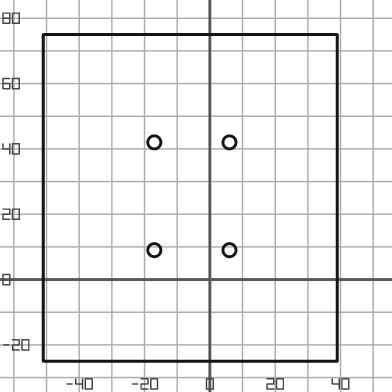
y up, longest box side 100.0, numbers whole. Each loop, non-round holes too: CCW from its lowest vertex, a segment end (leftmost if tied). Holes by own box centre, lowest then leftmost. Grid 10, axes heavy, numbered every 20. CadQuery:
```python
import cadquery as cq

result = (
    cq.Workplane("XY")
    .moveTo(-51.0, -25.0)
    .lineTo(39.0, -25.0)
    .lineTo(39.0, 75.0)
    .lineTo(-51.0, 75.0)
    .close()
    .moveTo(-17.0, 9.0)
    .circle(2.0)
    .moveTo(6.0, 9.0)
    .circle(2.0)
    .moveTo(-17.0, 42.0)
    .circle(2.0)
    .moveTo(6.0, 42.0)
    .circle(2.0)
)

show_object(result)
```